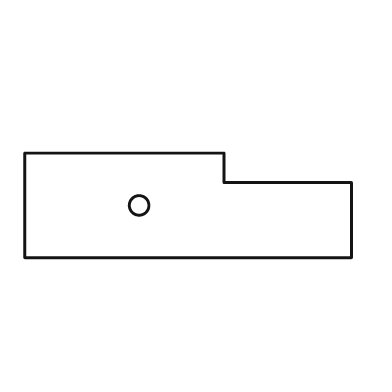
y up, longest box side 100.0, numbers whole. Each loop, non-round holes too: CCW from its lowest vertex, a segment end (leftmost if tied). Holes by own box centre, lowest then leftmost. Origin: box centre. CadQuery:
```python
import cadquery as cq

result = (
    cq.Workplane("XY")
    .moveTo(-50.0, -16.0)
    .lineTo(50.0, -16.0)
    .lineTo(50.0, 7.0)
    .lineTo(11.0, 7.0)
    .lineTo(11.0, 16.0)
    .lineTo(-50.0, 16.0)
    .close()
    .moveTo(-15.0, 0.0)
    .circle(3.0)
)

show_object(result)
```